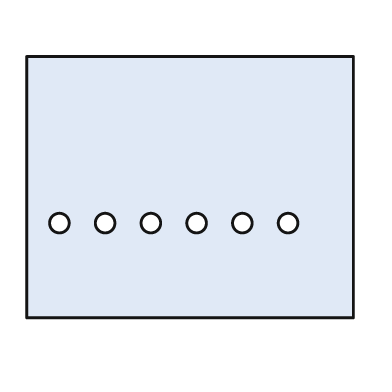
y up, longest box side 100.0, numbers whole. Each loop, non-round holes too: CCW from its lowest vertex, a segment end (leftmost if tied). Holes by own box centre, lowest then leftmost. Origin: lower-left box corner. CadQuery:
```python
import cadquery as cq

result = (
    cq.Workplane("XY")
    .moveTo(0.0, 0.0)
    .lineTo(100.0, 0.0)
    .lineTo(100.0, 80.0)
    .lineTo(0.0, 80.0)
    .close()
    .moveTo(10.0, 29.0)
    .circle(3.0)
    .moveTo(24.0, 29.0)
    .circle(3.0)
    .moveTo(38.0, 29.0)
    .circle(3.0)
    .moveTo(52.0, 29.0)
    .circle(3.0)
    .moveTo(66.0, 29.0)
    .circle(3.0)
    .moveTo(80.0, 29.0)
    .circle(3.0)
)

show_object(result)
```